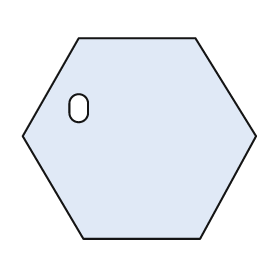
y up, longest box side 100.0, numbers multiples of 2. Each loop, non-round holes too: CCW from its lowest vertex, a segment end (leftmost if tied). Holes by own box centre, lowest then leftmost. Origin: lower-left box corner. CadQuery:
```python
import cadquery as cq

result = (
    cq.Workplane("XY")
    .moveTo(26.0, 0.0)
    .lineTo(76.0, 0.0)
    .lineTo(100.0, 44.0)
    .lineTo(74.0, 86.0)
    .lineTo(24.0, 86.0)
    .lineTo(0.0, 44.0)
    .close()
    .moveTo(20.0, 54.0)
    .threePointArc((24.0, 50.0), (28.0, 54.0))
    .lineTo(28.0, 58.0)
    .threePointArc((24.0, 62.0), (20.0, 58.0))
    .close()
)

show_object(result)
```